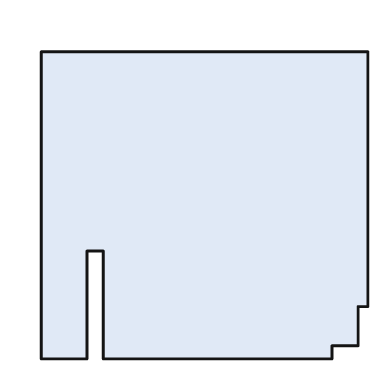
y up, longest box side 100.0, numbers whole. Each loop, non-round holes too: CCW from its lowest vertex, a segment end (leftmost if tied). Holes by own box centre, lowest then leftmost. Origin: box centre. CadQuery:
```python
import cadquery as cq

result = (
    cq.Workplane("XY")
    .moveTo(-50.0, -47.0)
    .lineTo(-36.0, -47.0)
    .lineTo(-36.0, -14.0)
    .lineTo(-31.0, -14.0)
    .lineTo(-31.0, -47.0)
    .lineTo(39.0, -47.0)
    .lineTo(39.0, -43.0)
    .lineTo(47.0, -43.0)
    .lineTo(47.0, -31.0)
    .lineTo(50.0, -31.0)
    .lineTo(50.0, 47.0)
    .lineTo(-50.0, 47.0)
    .close()
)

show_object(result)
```